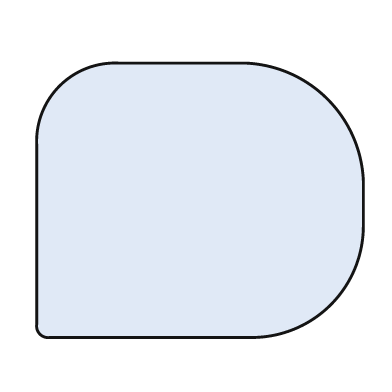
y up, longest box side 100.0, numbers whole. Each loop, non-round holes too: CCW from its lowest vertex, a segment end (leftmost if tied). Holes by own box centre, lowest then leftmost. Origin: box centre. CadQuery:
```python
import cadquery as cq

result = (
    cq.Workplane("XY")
    .moveTo(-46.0, -42.0)
    .lineTo(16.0, -42.0)
    .threePointArc((40.0, -32.0), (50.0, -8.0))
    .lineTo(50.0, 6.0)
    .threePointArc((39.0, 31.0), (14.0, 42.0))
    .lineTo(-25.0, 42.0)
    .threePointArc((-43.0, 35.0), (-50.0, 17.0))
    .lineTo(-50.0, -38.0)
    .threePointArc((-49.0, -41.0), (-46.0, -42.0))
    .close()
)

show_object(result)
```